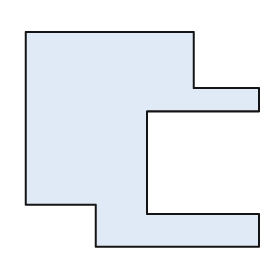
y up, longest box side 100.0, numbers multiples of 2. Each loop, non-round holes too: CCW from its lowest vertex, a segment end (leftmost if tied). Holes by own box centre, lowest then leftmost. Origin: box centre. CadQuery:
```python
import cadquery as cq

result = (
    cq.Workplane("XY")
    .moveTo(-20.0, -46.0)
    .lineTo(50.0, -46.0)
    .lineTo(50.0, -32.0)
    .lineTo(2.0, -32.0)
    .lineTo(2.0, 12.0)
    .lineTo(50.0, 12.0)
    .lineTo(50.0, 22.0)
    .lineTo(22.0, 22.0)
    .lineTo(22.0, 46.0)
    .lineTo(-50.0, 46.0)
    .lineTo(-50.0, -28.0)
    .lineTo(-20.0, -28.0)
    .close()
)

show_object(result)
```